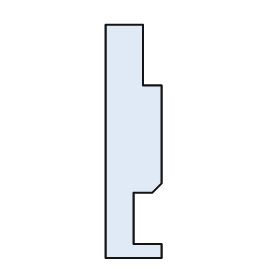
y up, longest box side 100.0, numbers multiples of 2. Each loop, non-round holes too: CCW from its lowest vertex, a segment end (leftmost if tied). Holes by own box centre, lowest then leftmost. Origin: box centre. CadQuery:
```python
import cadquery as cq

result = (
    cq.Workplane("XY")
    .moveTo(-12.0, -50.0)
    .lineTo(12.0, -50.0)
    .lineTo(12.0, -44.0)
    .lineTo(0.0, -44.0)
    .lineTo(0.0, -22.0)
    .lineTo(8.0, -22.0)
    .lineTo(12.0, -18.0)
    .lineTo(12.0, 24.0)
    .lineTo(4.0, 24.0)
    .lineTo(4.0, 50.0)
    .lineTo(-12.0, 50.0)
    .close()
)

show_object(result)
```